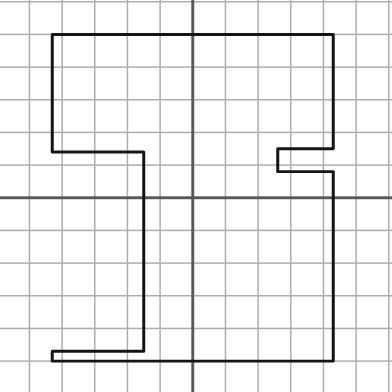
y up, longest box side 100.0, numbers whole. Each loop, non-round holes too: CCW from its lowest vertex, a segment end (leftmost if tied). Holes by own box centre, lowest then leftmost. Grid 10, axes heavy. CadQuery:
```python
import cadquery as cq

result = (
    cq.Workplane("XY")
    .moveTo(-43.0, -50.0)
    .lineTo(43.0, -50.0)
    .lineTo(43.0, 8.0)
    .lineTo(26.0, 8.0)
    .lineTo(26.0, 15.0)
    .lineTo(43.0, 15.0)
    .lineTo(43.0, 50.0)
    .lineTo(-43.0, 50.0)
    .lineTo(-43.0, 14.0)
    .lineTo(-15.0, 14.0)
    .lineTo(-15.0, -47.0)
    .lineTo(-43.0, -47.0)
    .close()
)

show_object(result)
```